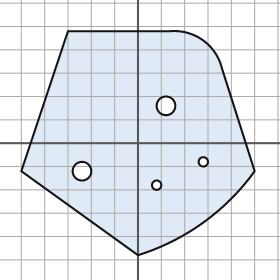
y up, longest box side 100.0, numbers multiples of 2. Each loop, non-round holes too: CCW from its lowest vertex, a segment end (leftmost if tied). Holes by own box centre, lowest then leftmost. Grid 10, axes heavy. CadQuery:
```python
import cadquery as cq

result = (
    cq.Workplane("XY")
    .moveTo(0.0, -48.0)
    .threePointArc((28.0, -34.0), (50.0, -12.0))
    .lineTo(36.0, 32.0)
    .threePointArc((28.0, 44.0), (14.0, 48.0))
    .lineTo(-30.0, 48.0)
    .lineTo(-50.0, -12.0)
    .close()
    .moveTo(8.0, -18.0)
    .circle(2.0)
    .moveTo(-24.0, -12.0)
    .circle(4.0)
    .moveTo(28.0, -8.0)
    .circle(2.0)
    .moveTo(12.0, 16.0)
    .circle(4.0)
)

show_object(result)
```